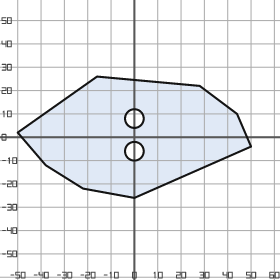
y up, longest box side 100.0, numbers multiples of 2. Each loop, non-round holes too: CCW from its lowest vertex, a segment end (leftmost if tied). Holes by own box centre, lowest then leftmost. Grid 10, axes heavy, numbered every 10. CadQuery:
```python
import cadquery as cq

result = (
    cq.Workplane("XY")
    .moveTo(0.0, -26.0)
    .lineTo(50.0, -4.0)
    .lineTo(44.0, 10.0)
    .lineTo(28.0, 22.0)
    .lineTo(-16.0, 26.0)
    .lineTo(-50.0, 2.0)
    .lineTo(-38.0, -12.0)
    .lineTo(-22.0, -22.0)
    .close()
    .moveTo(0.0, -6.0)
    .circle(4.0)
    .moveTo(0.0, 8.0)
    .circle(4.0)
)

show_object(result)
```